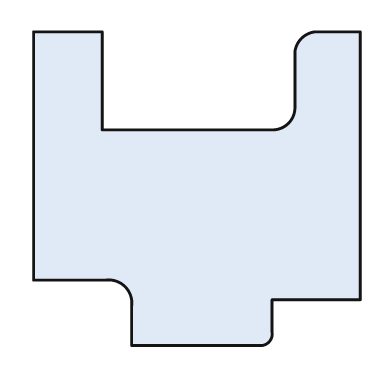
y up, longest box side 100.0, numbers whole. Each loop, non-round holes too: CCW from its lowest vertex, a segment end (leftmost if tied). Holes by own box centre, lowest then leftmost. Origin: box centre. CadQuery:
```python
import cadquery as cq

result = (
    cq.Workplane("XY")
    .moveTo(-20.0, -48.0)
    .lineTo(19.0, -48.0)
    .threePointArc((22.0, -47.0), (23.0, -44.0))
    .lineTo(23.0, -34.0)
    .lineTo(50.0, -34.0)
    .lineTo(50.0, 48.0)
    .lineTo(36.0, 48.0)
    .threePointArc((32.0, 46.0), (30.0, 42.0))
    .lineTo(30.0, 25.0)
    .threePointArc((28.0, 20.0), (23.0, 18.0))
    .lineTo(-29.0, 18.0)
    .lineTo(-29.0, 48.0)
    .lineTo(-50.0, 48.0)
    .lineTo(-50.0, -28.0)
    .lineTo(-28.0, -28.0)
    .threePointArc((-22.0, -30.0), (-20.0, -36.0))
    .close()
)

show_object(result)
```